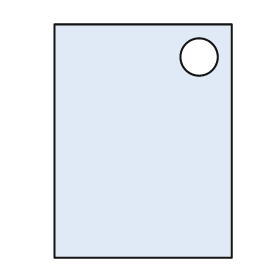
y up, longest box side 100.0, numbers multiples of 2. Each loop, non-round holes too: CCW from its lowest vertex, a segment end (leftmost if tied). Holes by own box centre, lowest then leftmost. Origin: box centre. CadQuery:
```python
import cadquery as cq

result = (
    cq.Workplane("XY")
    .moveTo(-38.0, -50.0)
    .lineTo(38.0, -50.0)
    .lineTo(38.0, 50.0)
    .lineTo(-38.0, 50.0)
    .close()
    .moveTo(24.0, 36.0)
    .circle(8.0)
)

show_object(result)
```